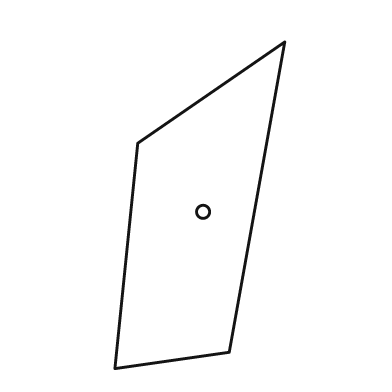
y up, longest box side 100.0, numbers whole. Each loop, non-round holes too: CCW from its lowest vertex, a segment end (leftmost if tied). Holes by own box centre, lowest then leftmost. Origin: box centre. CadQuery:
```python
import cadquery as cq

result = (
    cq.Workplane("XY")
    .moveTo(-26.0, -50.0)
    .lineTo(9.0, -45.0)
    .lineTo(26.0, 50.0)
    .lineTo(-19.0, 19.0)
    .close()
    .moveTo(1.0, -2.0)
    .circle(2.0)
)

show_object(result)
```